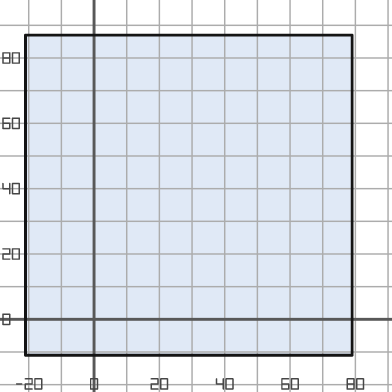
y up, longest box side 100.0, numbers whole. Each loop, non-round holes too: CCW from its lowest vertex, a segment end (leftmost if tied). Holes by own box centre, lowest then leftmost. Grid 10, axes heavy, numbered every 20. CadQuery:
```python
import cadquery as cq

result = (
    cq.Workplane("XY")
    .moveTo(-21.0, -11.0)
    .lineTo(79.0, -11.0)
    .lineTo(79.0, 87.0)
    .lineTo(-21.0, 87.0)
    .close()
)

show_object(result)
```